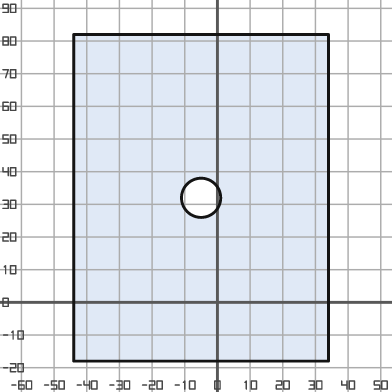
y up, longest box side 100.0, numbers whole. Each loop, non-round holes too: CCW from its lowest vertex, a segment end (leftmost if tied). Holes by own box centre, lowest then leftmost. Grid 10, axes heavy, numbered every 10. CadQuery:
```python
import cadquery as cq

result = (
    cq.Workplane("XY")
    .moveTo(-44.0, -18.0)
    .lineTo(34.0, -18.0)
    .lineTo(34.0, 82.0)
    .lineTo(-44.0, 82.0)
    .close()
    .moveTo(-5.0, 32.0)
    .circle(6.0)
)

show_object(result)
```